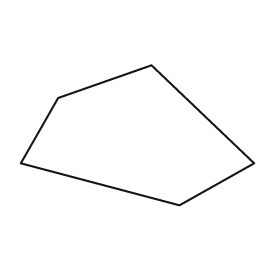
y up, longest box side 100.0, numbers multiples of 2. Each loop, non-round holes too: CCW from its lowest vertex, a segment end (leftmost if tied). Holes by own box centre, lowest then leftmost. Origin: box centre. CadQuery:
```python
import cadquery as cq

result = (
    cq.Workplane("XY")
    .moveTo(18.0, -30.0)
    .lineTo(50.0, -12.0)
    .lineTo(6.0, 30.0)
    .lineTo(-34.0, 16.0)
    .lineTo(-50.0, -12.0)
    .close()
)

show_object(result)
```